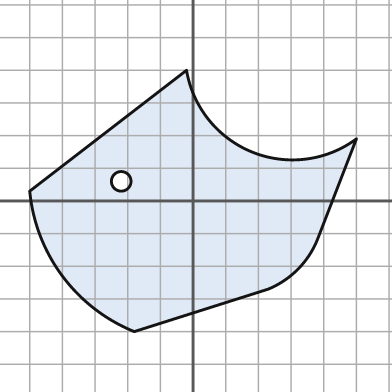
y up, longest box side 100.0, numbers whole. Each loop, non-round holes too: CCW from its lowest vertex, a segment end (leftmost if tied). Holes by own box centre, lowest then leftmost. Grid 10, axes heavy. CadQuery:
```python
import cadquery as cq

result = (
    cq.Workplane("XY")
    .moveTo(-18.0, -40.0)
    .lineTo(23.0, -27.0)
    .threePointArc((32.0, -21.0), (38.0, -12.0))
    .lineTo(50.0, 19.0)
    .threePointArc((18.0, 15.0), (-2.0, 40.0))
    .lineTo(-50.0, 3.0)
    .threePointArc((-40.0, -23.0), (-18.0, -40.0))
    .close()
    .moveTo(-22.0, 6.0)
    .circle(3.0)
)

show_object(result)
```